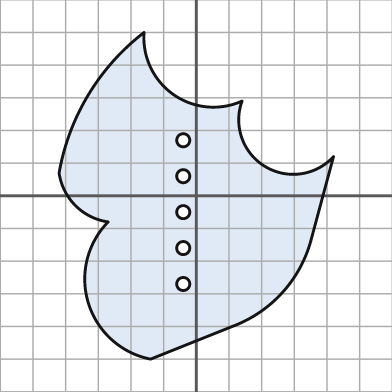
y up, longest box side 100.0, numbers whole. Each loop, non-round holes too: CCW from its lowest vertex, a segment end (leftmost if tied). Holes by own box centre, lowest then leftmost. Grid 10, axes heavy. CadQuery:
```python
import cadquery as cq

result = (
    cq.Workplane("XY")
    .moveTo(-14.0, -50.0)
    .lineTo(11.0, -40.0)
    .threePointArc((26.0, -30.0), (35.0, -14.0))
    .lineTo(42.0, 12.0)
    .threePointArc((21.0, 9.0), (14.0, 29.0))
    .threePointArc((-7.0, 31.0), (-16.0, 50.0))
    .threePointArc((-33.0, 31.0), (-42.0, 7.0))
    .threePointArc((-37.0, -3.0), (-27.0, -8.0))
    .threePointArc((-33.0, -33.0), (-14.0, -50.0))
    .close()
    .moveTo(-4.0, -27.0)
    .circle(2.0)
    .moveTo(-4.0, -16.0)
    .circle(2.0)
    .moveTo(-4.0, -5.0)
    .circle(2.0)
    .moveTo(-4.0, 6.0)
    .circle(2.0)
    .moveTo(-4.0, 17.0)
    .circle(2.0)
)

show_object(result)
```